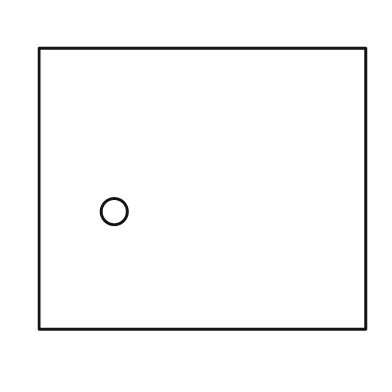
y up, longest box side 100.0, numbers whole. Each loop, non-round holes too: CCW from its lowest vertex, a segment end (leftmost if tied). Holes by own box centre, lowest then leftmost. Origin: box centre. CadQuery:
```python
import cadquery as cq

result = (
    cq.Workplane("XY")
    .moveTo(-50.0, -43.0)
    .lineTo(50.0, -43.0)
    .lineTo(50.0, 43.0)
    .lineTo(-50.0, 43.0)
    .close()
    .moveTo(-27.0, -7.0)
    .circle(4.0)
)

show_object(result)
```